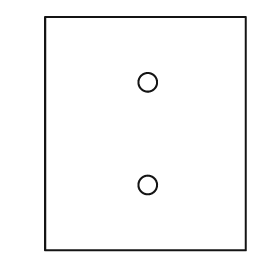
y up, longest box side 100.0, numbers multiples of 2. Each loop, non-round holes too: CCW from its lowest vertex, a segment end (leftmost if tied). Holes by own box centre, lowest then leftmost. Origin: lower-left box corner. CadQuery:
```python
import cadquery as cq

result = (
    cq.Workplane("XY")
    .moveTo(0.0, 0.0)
    .lineTo(86.0, 0.0)
    .lineTo(86.0, 100.0)
    .lineTo(0.0, 100.0)
    .close()
    .moveTo(44.0, 28.0)
    .circle(4.0)
    .moveTo(44.0, 72.0)
    .circle(4.0)
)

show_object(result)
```